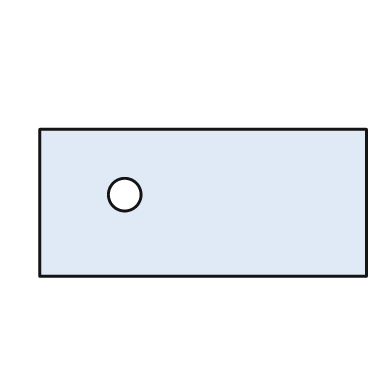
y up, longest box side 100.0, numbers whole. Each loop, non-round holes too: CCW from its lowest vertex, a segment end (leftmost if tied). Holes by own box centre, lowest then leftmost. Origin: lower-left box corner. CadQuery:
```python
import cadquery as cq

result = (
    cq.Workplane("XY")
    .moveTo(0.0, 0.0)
    .lineTo(100.0, 0.0)
    .lineTo(100.0, 45.0)
    .lineTo(0.0, 45.0)
    .close()
    .moveTo(26.0, 25.0)
    .circle(5.0)
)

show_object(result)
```